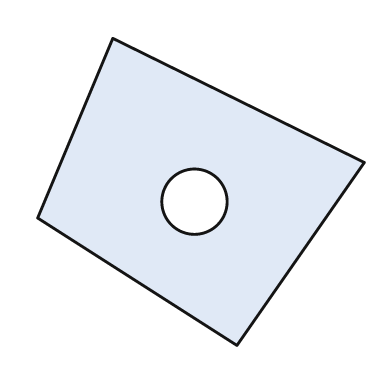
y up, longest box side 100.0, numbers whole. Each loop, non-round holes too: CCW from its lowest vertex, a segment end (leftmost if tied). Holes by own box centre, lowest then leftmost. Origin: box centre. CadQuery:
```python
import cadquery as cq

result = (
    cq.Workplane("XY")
    .moveTo(11.0, -47.0)
    .lineTo(50.0, 9.0)
    .lineTo(-27.0, 47.0)
    .lineTo(-50.0, -8.0)
    .close()
    .moveTo(-2.0, -3.0)
    .circle(10.0)
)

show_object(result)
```